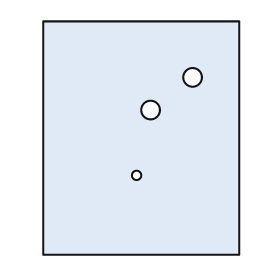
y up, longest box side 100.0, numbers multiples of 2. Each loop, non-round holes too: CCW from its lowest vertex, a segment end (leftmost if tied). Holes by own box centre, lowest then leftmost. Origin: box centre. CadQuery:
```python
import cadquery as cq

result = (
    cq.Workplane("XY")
    .moveTo(-42.0, -50.0)
    .lineTo(42.0, -50.0)
    .lineTo(42.0, 50.0)
    .lineTo(-42.0, 50.0)
    .close()
    .moveTo(-2.0, -16.0)
    .circle(2.0)
    .moveTo(4.0, 12.0)
    .circle(4.0)
    .moveTo(22.0, 26.0)
    .circle(4.0)
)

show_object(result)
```